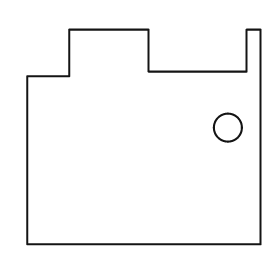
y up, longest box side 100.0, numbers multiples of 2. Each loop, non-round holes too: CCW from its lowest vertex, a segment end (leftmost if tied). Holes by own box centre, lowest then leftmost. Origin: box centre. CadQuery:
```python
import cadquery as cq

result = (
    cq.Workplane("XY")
    .moveTo(-50.0, -46.0)
    .lineTo(50.0, -46.0)
    .lineTo(50.0, 46.0)
    .lineTo(44.0, 46.0)
    .lineTo(44.0, 28.0)
    .lineTo(2.0, 28.0)
    .lineTo(2.0, 46.0)
    .lineTo(-32.0, 46.0)
    .lineTo(-32.0, 26.0)
    .lineTo(-50.0, 26.0)
    .close()
    .moveTo(36.0, 4.0)
    .circle(6.0)
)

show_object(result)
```